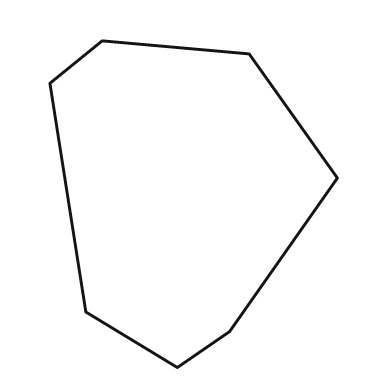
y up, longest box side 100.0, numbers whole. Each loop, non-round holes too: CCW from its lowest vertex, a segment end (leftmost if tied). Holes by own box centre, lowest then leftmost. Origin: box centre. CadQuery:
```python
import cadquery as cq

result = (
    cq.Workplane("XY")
    .moveTo(-5.0, -50.0)
    .lineTo(11.0, -39.0)
    .lineTo(44.0, 8.0)
    .lineTo(17.0, 46.0)
    .lineTo(-28.0, 50.0)
    .lineTo(-44.0, 37.0)
    .lineTo(-33.0, -33.0)
    .close()
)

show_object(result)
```